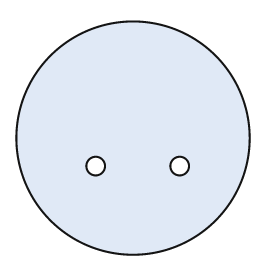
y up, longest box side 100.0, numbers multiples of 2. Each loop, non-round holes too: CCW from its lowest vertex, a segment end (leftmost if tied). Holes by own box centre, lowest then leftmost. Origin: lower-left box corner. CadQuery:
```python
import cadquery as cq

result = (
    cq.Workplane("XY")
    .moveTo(50.0, 50.0)
    .circle(50.0)
    .moveTo(34.0, 38.0)
    .circle(4.0)
    .moveTo(70.0, 38.0)
    .circle(4.0)
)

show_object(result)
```